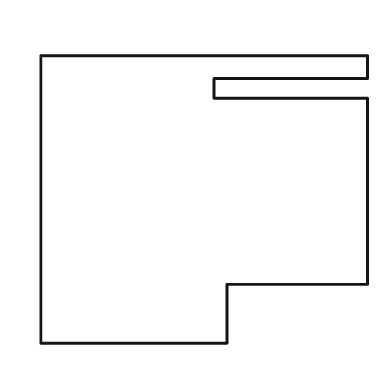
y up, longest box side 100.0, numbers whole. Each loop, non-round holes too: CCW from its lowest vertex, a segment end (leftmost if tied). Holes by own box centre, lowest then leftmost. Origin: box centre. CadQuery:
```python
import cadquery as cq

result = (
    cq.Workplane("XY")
    .moveTo(-50.0, -44.0)
    .lineTo(7.0, -44.0)
    .lineTo(7.0, -26.0)
    .lineTo(50.0, -26.0)
    .lineTo(50.0, 31.0)
    .lineTo(3.0, 31.0)
    .lineTo(3.0, 37.0)
    .lineTo(50.0, 37.0)
    .lineTo(50.0, 44.0)
    .lineTo(-50.0, 44.0)
    .close()
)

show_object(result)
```